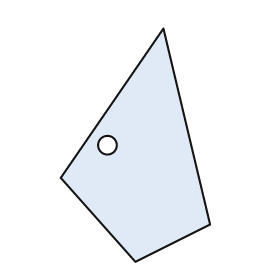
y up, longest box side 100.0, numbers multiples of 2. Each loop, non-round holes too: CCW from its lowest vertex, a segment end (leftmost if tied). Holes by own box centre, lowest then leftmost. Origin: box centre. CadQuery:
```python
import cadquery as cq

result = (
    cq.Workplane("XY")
    .moveTo(0.0, -50.0)
    .lineTo(32.0, -34.0)
    .lineTo(12.0, 50.0)
    .lineTo(-32.0, -14.0)
    .close()
    .moveTo(-12.0, 0.0)
    .circle(4.0)
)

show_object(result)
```